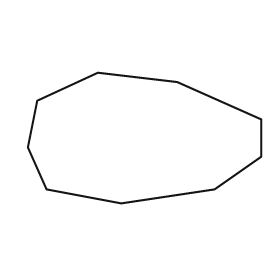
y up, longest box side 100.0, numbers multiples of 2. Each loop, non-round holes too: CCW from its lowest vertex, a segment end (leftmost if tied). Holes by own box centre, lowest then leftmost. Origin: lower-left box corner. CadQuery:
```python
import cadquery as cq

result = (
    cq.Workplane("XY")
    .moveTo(40.0, 0.0)
    .lineTo(80.0, 6.0)
    .lineTo(100.0, 20.0)
    .lineTo(100.0, 36.0)
    .lineTo(64.0, 52.0)
    .lineTo(30.0, 56.0)
    .lineTo(4.0, 44.0)
    .lineTo(0.0, 24.0)
    .lineTo(8.0, 6.0)
    .close()
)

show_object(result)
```